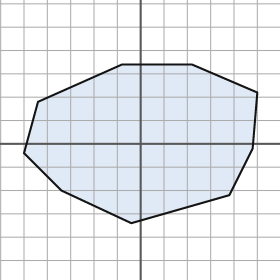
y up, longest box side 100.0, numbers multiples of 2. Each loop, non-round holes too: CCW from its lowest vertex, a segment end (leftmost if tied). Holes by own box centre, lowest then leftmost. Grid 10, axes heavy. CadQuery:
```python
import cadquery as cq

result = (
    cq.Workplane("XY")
    .moveTo(-4.0, -34.0)
    .lineTo(38.0, -22.0)
    .lineTo(48.0, -2.0)
    .lineTo(50.0, 22.0)
    .lineTo(22.0, 34.0)
    .lineTo(-8.0, 34.0)
    .lineTo(-44.0, 18.0)
    .lineTo(-50.0, -4.0)
    .lineTo(-34.0, -20.0)
    .close()
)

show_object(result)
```